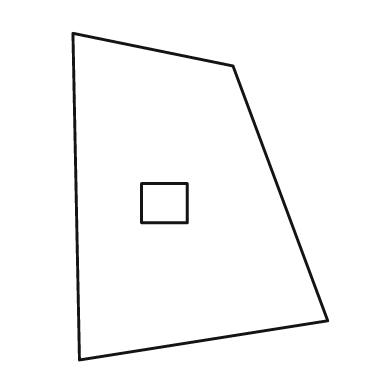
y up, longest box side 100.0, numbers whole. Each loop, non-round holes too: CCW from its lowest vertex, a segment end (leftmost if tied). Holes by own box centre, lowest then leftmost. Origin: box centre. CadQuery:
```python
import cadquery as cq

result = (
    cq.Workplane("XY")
    .moveTo(-37.0, -50.0)
    .lineTo(39.0, -38.0)
    .lineTo(10.0, 40.0)
    .lineTo(-39.0, 50.0)
    .close()
    .moveTo(-18.0, -8.0)
    .lineTo(-4.0, -8.0)
    .lineTo(-4.0, 4.0)
    .lineTo(-18.0, 4.0)
    .close()
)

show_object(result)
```